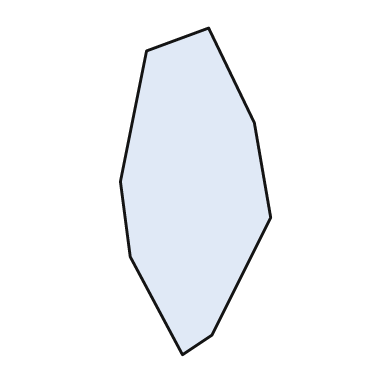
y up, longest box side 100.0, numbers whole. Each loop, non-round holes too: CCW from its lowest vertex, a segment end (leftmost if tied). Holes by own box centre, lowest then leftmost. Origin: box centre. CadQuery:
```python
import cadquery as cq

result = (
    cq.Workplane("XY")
    .moveTo(-4.0, -50.0)
    .lineTo(5.0, -44.0)
    .lineTo(23.0, -8.0)
    .lineTo(18.0, 21.0)
    .lineTo(4.0, 50.0)
    .lineTo(-15.0, 43.0)
    .lineTo(-23.0, 3.0)
    .lineTo(-20.0, -20.0)
    .close()
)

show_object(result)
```